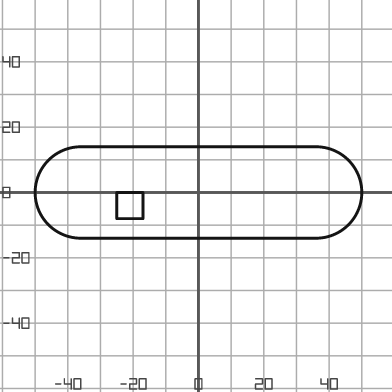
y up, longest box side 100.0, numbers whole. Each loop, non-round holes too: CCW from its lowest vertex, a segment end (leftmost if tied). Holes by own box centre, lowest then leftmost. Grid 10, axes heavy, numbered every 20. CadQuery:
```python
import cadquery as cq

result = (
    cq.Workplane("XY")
    .moveTo(-36.0, -14.0)
    .lineTo(36.0, -14.0)
    .threePointArc((50.0, 0.0), (36.0, 14.0))
    .lineTo(-36.0, 14.0)
    .threePointArc((-50.0, 0.0), (-36.0, -14.0))
    .close()
    .moveTo(-25.0, -8.0)
    .lineTo(-17.0, -8.0)
    .lineTo(-17.0, 0.0)
    .lineTo(-25.0, 0.0)
    .close()
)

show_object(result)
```